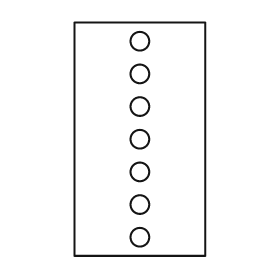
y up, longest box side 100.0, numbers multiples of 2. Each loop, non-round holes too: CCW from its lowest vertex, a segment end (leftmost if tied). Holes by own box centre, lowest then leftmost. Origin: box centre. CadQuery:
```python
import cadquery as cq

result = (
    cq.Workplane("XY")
    .moveTo(-28.0, -50.0)
    .lineTo(28.0, -50.0)
    .lineTo(28.0, 50.0)
    .lineTo(-28.0, 50.0)
    .close()
    .moveTo(0.0, -42.0)
    .circle(4.0)
    .moveTo(0.0, -28.0)
    .circle(4.0)
    .moveTo(0.0, -14.0)
    .circle(4.0)
    .moveTo(0.0, 0.0)
    .circle(4.0)
    .moveTo(0.0, 14.0)
    .circle(4.0)
    .moveTo(0.0, 28.0)
    .circle(4.0)
    .moveTo(0.0, 42.0)
    .circle(4.0)
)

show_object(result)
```